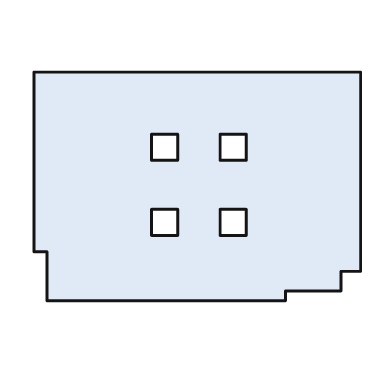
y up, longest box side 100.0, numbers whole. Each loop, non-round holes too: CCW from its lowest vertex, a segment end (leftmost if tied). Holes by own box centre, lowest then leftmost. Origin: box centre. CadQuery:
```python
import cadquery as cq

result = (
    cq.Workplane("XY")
    .moveTo(-46.0, -35.0)
    .lineTo(27.0, -35.0)
    .lineTo(27.0, -32.0)
    .lineTo(44.0, -32.0)
    .lineTo(44.0, -26.0)
    .lineTo(50.0, -26.0)
    .lineTo(50.0, 35.0)
    .lineTo(-50.0, 35.0)
    .lineTo(-50.0, -20.0)
    .lineTo(-46.0, -20.0)
    .close()
    .moveTo(-14.0, -15.0)
    .lineTo(-6.0, -15.0)
    .lineTo(-6.0, -7.0)
    .lineTo(-14.0, -7.0)
    .close()
    .moveTo(7.0, -15.0)
    .lineTo(15.0, -15.0)
    .lineTo(15.0, -7.0)
    .lineTo(7.0, -7.0)
    .close()
    .moveTo(-14.0, 8.0)
    .lineTo(-6.0, 8.0)
    .lineTo(-6.0, 16.0)
    .lineTo(-14.0, 16.0)
    .close()
    .moveTo(7.0, 8.0)
    .lineTo(15.0, 8.0)
    .lineTo(15.0, 16.0)
    .lineTo(7.0, 16.0)
    .close()
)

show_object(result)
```